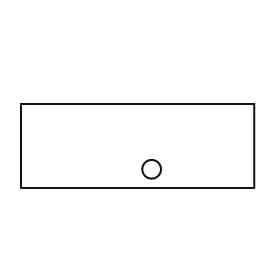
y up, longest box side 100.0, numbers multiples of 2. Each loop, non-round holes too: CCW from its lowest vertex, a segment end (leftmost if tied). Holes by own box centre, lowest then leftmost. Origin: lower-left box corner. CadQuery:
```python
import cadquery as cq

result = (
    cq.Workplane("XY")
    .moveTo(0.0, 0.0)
    .lineTo(100.0, 0.0)
    .lineTo(100.0, 36.0)
    .lineTo(0.0, 36.0)
    .close()
    .moveTo(56.0, 8.0)
    .circle(4.0)
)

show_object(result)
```